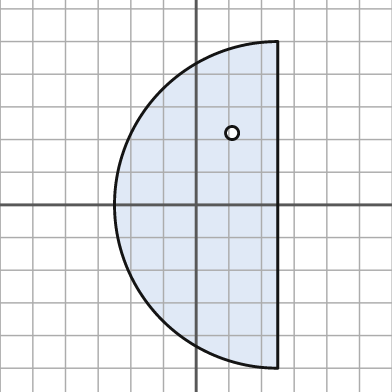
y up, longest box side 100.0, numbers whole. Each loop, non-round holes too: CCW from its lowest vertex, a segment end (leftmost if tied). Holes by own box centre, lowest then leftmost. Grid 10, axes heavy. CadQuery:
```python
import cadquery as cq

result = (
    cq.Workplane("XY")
    .moveTo(25.0, -50.0)
    .lineTo(25.0, 50.0)
    .threePointArc((-25.0, 0.0), (25.0, -50.0))
    .close()
    .moveTo(11.0, 22.0)
    .circle(2.0)
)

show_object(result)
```